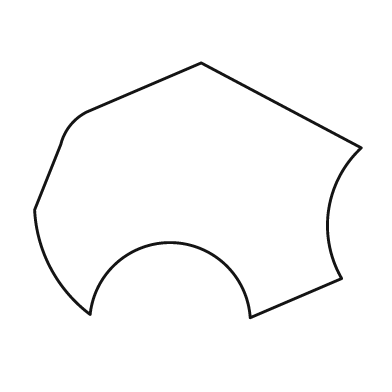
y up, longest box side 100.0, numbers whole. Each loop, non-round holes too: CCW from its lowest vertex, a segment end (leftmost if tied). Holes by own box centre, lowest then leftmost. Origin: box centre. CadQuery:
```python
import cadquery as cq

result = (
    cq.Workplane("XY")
    .moveTo(16.0, -39.0)
    .lineTo(44.0, -27.0)
    .threePointArc((40.0, -6.0), (50.0, 13.0))
    .lineTo(1.0, 39.0)
    .lineTo(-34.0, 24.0)
    .threePointArc((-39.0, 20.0), (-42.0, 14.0))
    .lineTo(-50.0, -6.0)
    .threePointArc((-45.0, -24.0), (-33.0, -38.0))
    .threePointArc((-8.0, -16.0), (16.0, -39.0))
    .close()
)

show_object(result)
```